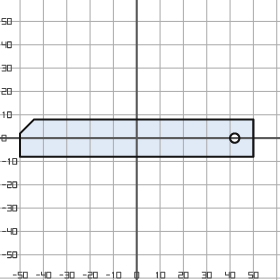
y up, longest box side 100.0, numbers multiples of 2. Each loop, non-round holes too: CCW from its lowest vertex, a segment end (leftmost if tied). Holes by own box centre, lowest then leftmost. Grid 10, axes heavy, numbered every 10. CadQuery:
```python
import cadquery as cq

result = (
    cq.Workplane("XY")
    .moveTo(-50.0, -8.0)
    .lineTo(50.0, -8.0)
    .lineTo(50.0, 8.0)
    .lineTo(-44.0, 8.0)
    .lineTo(-50.0, 2.0)
    .close()
    .moveTo(42.0, 0.0)
    .circle(2.0)
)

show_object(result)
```